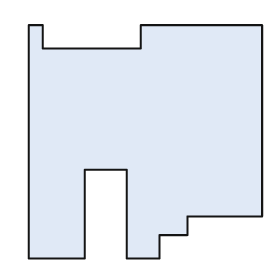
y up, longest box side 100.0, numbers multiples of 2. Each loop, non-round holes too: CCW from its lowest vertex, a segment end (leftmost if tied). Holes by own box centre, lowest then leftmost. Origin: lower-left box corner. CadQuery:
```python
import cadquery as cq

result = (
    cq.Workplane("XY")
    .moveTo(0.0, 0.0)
    .lineTo(24.0, 0.0)
    .lineTo(24.0, 38.0)
    .lineTo(42.0, 38.0)
    .lineTo(42.0, 0.0)
    .lineTo(56.0, 0.0)
    .lineTo(56.0, 10.0)
    .lineTo(68.0, 10.0)
    .lineTo(68.0, 18.0)
    .lineTo(100.0, 18.0)
    .lineTo(100.0, 100.0)
    .lineTo(48.0, 100.0)
    .lineTo(48.0, 90.0)
    .lineTo(6.0, 90.0)
    .lineTo(6.0, 100.0)
    .lineTo(0.0, 100.0)
    .close()
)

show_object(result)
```